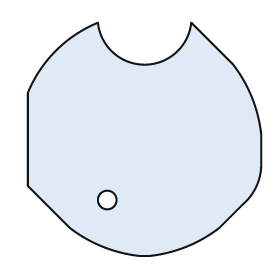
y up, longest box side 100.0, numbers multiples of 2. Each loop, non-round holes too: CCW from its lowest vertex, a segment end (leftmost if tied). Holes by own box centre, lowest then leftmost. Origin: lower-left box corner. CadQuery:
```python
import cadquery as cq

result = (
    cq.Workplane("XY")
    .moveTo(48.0, 0.0)
    .lineTo(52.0, 0.0)
    .threePointArc((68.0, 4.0), (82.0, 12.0))
    .lineTo(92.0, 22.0)
    .threePointArc((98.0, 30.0), (100.0, 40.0))
    .lineTo(100.0, 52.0)
    .threePointArc((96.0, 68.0), (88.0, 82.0))
    .lineTo(70.0, 100.0)
    .threePointArc((50.0, 82.0), (30.0, 100.0))
    .threePointArc((12.0, 88.0), (0.0, 70.0))
    .lineTo(0.0, 30.0)
    .lineTo(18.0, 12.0)
    .threePointArc((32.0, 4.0), (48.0, 0.0))
    .close()
    .moveTo(34.0, 24.0)
    .circle(4.0)
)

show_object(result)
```